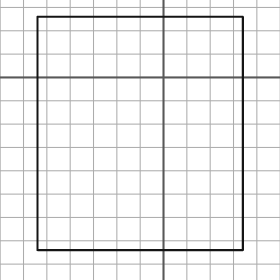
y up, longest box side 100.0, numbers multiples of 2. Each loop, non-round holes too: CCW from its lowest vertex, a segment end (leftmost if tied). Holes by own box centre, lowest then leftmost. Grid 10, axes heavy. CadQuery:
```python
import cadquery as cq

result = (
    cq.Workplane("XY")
    .moveTo(-54.0, -74.0)
    .lineTo(34.0, -74.0)
    .lineTo(34.0, 26.0)
    .lineTo(-54.0, 26.0)
    .close()
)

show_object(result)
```